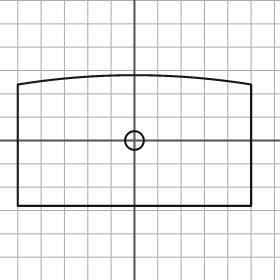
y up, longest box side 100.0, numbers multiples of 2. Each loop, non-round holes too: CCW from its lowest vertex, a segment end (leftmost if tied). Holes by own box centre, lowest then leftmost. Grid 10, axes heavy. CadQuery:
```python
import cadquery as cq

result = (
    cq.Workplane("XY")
    .moveTo(-50.0, -28.0)
    .lineTo(50.0, -28.0)
    .lineTo(50.0, 24.0)
    .threePointArc((0.0, 28.0), (-50.0, 24.0))
    .close()
    .moveTo(0.0, 0.0)
    .circle(4.0)
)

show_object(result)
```